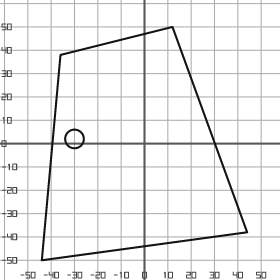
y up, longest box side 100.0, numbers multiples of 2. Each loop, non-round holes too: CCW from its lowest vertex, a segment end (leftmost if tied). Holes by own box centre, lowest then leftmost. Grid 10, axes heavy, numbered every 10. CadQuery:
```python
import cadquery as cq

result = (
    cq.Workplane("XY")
    .moveTo(-44.0, -50.0)
    .lineTo(44.0, -38.0)
    .lineTo(12.0, 50.0)
    .lineTo(-36.0, 38.0)
    .close()
    .moveTo(-30.0, 2.0)
    .circle(4.0)
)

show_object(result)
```